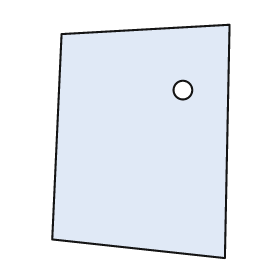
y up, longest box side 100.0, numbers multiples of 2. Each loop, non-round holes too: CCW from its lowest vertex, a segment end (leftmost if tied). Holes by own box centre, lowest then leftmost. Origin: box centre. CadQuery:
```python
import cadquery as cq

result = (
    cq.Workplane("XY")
    .moveTo(36.0, -50.0)
    .lineTo(38.0, 50.0)
    .lineTo(-34.0, 46.0)
    .lineTo(-38.0, -42.0)
    .close()
    .moveTo(18.0, 22.0)
    .circle(4.0)
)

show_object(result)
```